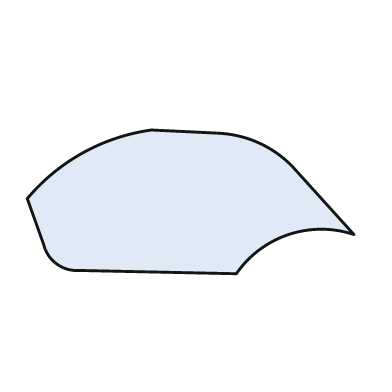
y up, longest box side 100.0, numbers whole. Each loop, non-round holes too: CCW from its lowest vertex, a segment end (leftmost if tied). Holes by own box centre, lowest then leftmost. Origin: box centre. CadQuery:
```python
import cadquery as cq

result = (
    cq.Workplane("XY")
    .moveTo(14.0, -22.0)
    .threePointArc((30.0, -10.0), (50.0, -10.0))
    .lineTo(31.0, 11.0)
    .threePointArc((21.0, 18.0), (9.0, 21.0))
    .lineTo(-12.0, 22.0)
    .threePointArc((-33.0, 15.0), (-50.0, 1.0))
    .lineTo(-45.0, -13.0)
    .threePointArc((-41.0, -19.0), (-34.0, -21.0))
    .close()
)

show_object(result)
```